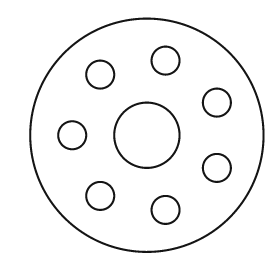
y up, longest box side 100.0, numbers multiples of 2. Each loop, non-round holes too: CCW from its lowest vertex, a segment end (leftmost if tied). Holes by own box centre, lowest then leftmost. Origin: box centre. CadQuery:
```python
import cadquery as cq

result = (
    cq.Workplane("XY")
    .moveTo(0.0, 0.0)
    .circle(50.0)
    .moveTo(8.0, -32.0)
    .circle(6.0)
    .moveTo(-20.0, -26.0)
    .circle(6.0)
    .moveTo(30.0, -14.0)
    .circle(6.0)
    .moveTo(-32.0, 0.0)
    .circle(6.0)
    .moveTo(0.0, 0.0)
    .circle(14.0)
    .moveTo(30.0, 14.0)
    .circle(6.0)
    .moveTo(-20.0, 26.0)
    .circle(6.0)
    .moveTo(8.0, 32.0)
    .circle(6.0)
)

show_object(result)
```